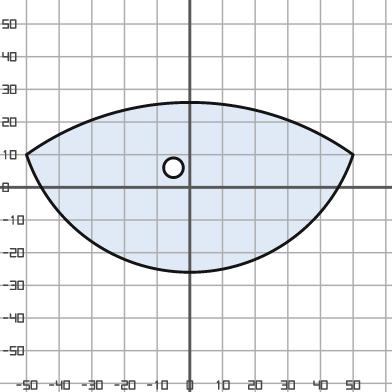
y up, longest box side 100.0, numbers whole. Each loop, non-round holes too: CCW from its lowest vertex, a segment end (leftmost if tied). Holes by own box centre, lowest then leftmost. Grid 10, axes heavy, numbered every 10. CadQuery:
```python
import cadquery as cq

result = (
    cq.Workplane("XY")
    .moveTo(-50.0, 10.0)
    .threePointArc((0.0, -26.0), (50.0, 10.0))
    .threePointArc((0.0, 26.0), (-50.0, 10.0))
    .close()
    .moveTo(-5.0, 6.0)
    .circle(3.0)
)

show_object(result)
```